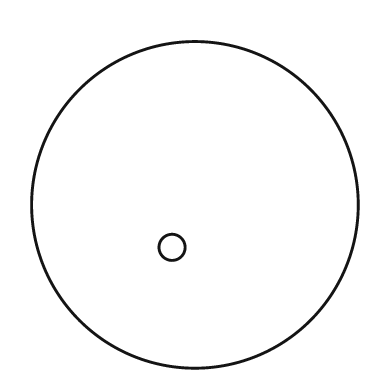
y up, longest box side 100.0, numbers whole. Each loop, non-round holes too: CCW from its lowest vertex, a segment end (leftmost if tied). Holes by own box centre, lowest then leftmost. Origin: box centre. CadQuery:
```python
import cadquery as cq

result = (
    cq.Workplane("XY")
    .moveTo(0.0, 0.0)
    .circle(50.0)
    .moveTo(-7.0, -13.0)
    .circle(4.0)
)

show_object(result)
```